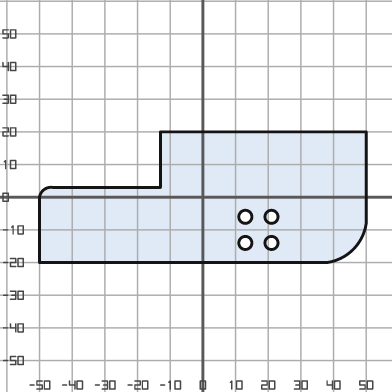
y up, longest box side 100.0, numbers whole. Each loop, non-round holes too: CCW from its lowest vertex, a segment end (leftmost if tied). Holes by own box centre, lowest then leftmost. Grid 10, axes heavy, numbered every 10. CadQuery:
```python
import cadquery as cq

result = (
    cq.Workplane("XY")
    .moveTo(-50.0, -20.0)
    .lineTo(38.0, -20.0)
    .threePointArc((46.0, -16.0), (50.0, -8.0))
    .lineTo(50.0, 20.0)
    .lineTo(-13.0, 20.0)
    .lineTo(-13.0, 3.0)
    .lineTo(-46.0, 3.0)
    .threePointArc((-49.0, 2.0), (-50.0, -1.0))
    .close()
    .moveTo(13.0, -14.0)
    .circle(2.0)
    .moveTo(21.0, -14.0)
    .circle(2.0)
    .moveTo(13.0, -6.0)
    .circle(2.0)
    .moveTo(21.0, -6.0)
    .circle(2.0)
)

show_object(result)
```